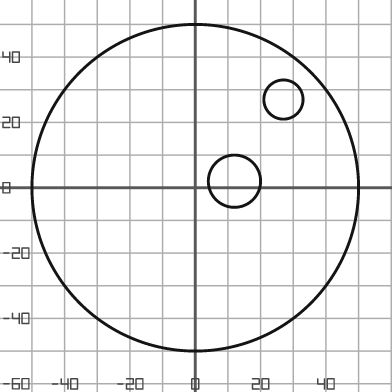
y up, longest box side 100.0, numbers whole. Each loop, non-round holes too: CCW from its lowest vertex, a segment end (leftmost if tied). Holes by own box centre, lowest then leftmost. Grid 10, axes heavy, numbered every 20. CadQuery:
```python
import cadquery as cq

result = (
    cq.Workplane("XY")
    .moveTo(0.0, 0.0)
    .circle(50.0)
    .moveTo(12.0, 2.0)
    .circle(8.0)
    .moveTo(27.0, 27.0)
    .circle(6.0)
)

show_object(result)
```